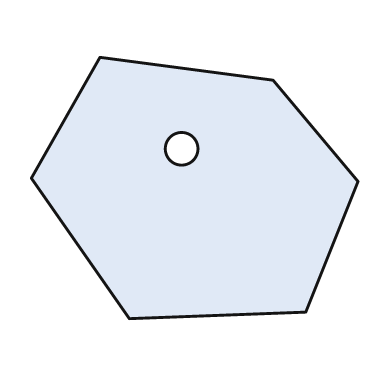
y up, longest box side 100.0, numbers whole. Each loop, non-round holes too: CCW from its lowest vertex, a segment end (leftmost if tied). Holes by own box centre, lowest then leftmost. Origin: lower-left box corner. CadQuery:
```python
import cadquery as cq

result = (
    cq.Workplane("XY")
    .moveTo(30.0, 0.0)
    .lineTo(84.0, 2.0)
    .lineTo(100.0, 42.0)
    .lineTo(74.0, 73.0)
    .lineTo(21.0, 80.0)
    .lineTo(0.0, 43.0)
    .close()
    .moveTo(46.0, 52.0)
    .circle(5.0)
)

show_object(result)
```